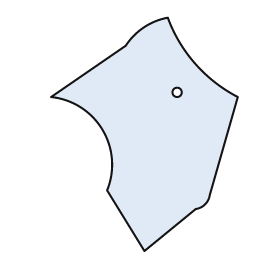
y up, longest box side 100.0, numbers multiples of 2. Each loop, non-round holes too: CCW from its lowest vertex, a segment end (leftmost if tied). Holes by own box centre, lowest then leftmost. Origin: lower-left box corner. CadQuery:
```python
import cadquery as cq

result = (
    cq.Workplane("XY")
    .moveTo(40.0, 0.0)
    .lineTo(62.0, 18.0)
    .threePointArc((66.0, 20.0), (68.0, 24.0))
    .lineTo(80.0, 66.0)
    .threePointArc((62.0, 80.0), (50.0, 100.0))
    .threePointArc((40.0, 96.0), (32.0, 88.0))
    .lineTo(0.0, 66.0)
    .threePointArc((22.0, 52.0), (24.0, 26.0))
    .close()
    .moveTo(54.0, 68.0)
    .circle(2.0)
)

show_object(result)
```